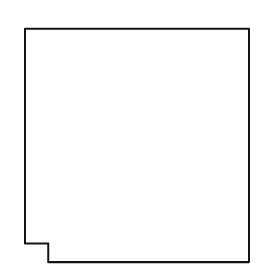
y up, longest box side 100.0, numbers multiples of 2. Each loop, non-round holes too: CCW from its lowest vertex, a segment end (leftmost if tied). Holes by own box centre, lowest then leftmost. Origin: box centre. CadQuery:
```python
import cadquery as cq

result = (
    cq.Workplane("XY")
    .moveTo(-38.0, -50.0)
    .lineTo(48.0, -50.0)
    .lineTo(48.0, 50.0)
    .lineTo(-48.0, 50.0)
    .lineTo(-48.0, -42.0)
    .lineTo(-38.0, -42.0)
    .close()
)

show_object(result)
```